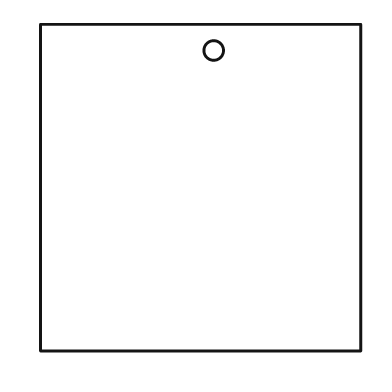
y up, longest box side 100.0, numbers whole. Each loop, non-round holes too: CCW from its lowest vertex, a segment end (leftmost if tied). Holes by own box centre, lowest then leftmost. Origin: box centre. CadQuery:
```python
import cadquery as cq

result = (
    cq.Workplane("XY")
    .moveTo(-49.0, -50.0)
    .lineTo(49.0, -50.0)
    .lineTo(49.0, 50.0)
    .lineTo(-49.0, 50.0)
    .close()
    .moveTo(4.0, 42.0)
    .circle(3.0)
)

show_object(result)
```